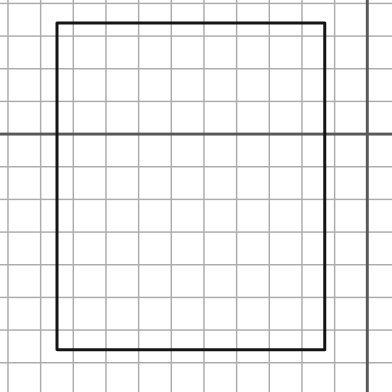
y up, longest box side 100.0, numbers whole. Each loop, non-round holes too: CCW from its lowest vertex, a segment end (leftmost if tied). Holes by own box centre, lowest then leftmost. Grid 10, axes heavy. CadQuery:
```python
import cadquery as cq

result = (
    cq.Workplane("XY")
    .moveTo(-95.0, -66.0)
    .lineTo(-13.0, -66.0)
    .lineTo(-13.0, 34.0)
    .lineTo(-95.0, 34.0)
    .close()
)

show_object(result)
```